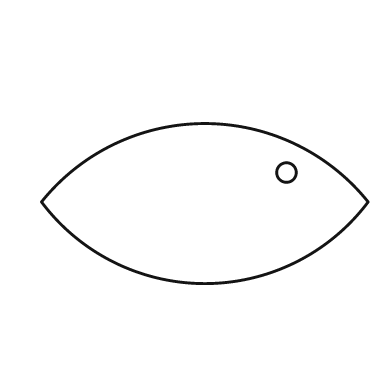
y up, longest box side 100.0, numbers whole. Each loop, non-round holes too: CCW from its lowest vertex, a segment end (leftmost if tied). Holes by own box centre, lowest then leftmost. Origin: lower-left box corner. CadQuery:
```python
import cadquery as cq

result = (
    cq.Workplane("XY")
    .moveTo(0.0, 25.0)
    .threePointArc((50.0, 0.0), (100.0, 25.0))
    .threePointArc((50.0, 49.0), (0.0, 25.0))
    .close()
    .moveTo(75.0, 34.0)
    .circle(3.0)
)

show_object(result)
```